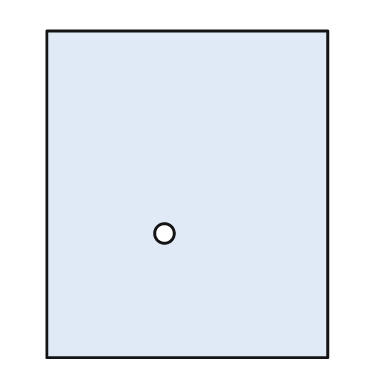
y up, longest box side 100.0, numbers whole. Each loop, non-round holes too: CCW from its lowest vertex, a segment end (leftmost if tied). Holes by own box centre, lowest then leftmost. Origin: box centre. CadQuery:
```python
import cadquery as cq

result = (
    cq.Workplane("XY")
    .moveTo(-43.0, -50.0)
    .lineTo(43.0, -50.0)
    .lineTo(43.0, 50.0)
    .lineTo(-43.0, 50.0)
    .close()
    .moveTo(-7.0, -12.0)
    .circle(3.0)
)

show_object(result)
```